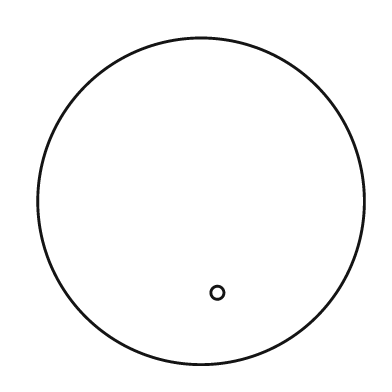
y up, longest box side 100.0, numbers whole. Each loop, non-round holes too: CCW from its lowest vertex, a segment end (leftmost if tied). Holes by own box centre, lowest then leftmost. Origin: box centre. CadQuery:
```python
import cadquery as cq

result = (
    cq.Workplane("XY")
    .moveTo(0.0, 0.0)
    .circle(50.0)
    .moveTo(5.0, -28.0)
    .circle(2.0)
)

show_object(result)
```